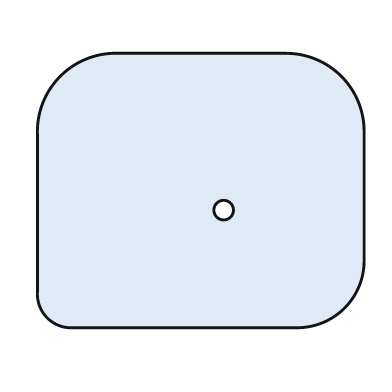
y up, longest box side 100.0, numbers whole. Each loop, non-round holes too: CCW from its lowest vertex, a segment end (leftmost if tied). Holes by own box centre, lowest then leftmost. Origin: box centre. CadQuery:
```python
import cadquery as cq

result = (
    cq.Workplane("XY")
    .moveTo(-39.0, -42.0)
    .lineTo(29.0, -42.0)
    .threePointArc((44.0, -36.0), (50.0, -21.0))
    .lineTo(50.0, 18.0)
    .threePointArc((43.0, 35.0), (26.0, 42.0))
    .lineTo(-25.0, 42.0)
    .threePointArc((-43.0, 35.0), (-50.0, 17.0))
    .lineTo(-50.0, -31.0)
    .threePointArc((-47.0, -39.0), (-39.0, -42.0))
    .close()
    .moveTo(7.0, -6.0)
    .circle(3.0)
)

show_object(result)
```